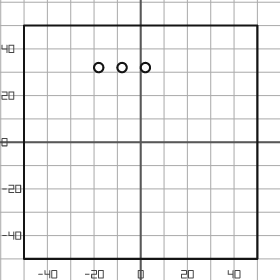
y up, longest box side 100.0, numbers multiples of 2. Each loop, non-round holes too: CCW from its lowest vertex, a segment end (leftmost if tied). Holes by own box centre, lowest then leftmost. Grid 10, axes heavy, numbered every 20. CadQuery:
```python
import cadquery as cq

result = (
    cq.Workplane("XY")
    .moveTo(-50.0, -50.0)
    .lineTo(50.0, -50.0)
    .lineTo(50.0, 50.0)
    .lineTo(-50.0, 50.0)
    .close()
    .moveTo(-18.0, 32.0)
    .circle(2.0)
    .moveTo(-8.0, 32.0)
    .circle(2.0)
    .moveTo(2.0, 32.0)
    .circle(2.0)
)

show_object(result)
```